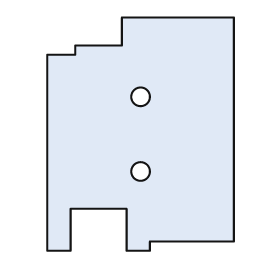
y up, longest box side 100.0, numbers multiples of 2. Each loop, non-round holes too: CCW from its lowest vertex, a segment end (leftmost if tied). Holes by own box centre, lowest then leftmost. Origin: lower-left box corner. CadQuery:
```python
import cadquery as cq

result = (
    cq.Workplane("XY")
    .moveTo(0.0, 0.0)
    .lineTo(10.0, 0.0)
    .lineTo(10.0, 18.0)
    .lineTo(34.0, 18.0)
    .lineTo(34.0, 0.0)
    .lineTo(44.0, 0.0)
    .lineTo(44.0, 4.0)
    .lineTo(80.0, 4.0)
    .lineTo(80.0, 100.0)
    .lineTo(32.0, 100.0)
    .lineTo(32.0, 88.0)
    .lineTo(12.0, 88.0)
    .lineTo(12.0, 84.0)
    .lineTo(0.0, 84.0)
    .close()
    .moveTo(40.0, 34.0)
    .circle(4.0)
    .moveTo(40.0, 66.0)
    .circle(4.0)
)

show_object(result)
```